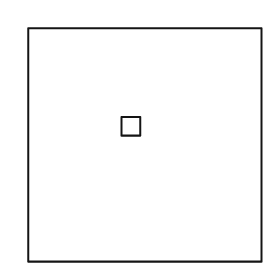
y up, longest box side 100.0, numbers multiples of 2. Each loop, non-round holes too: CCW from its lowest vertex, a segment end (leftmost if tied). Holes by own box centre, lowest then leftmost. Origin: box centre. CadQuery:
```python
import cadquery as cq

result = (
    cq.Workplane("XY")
    .moveTo(-50.0, -50.0)
    .lineTo(50.0, -50.0)
    .lineTo(50.0, 50.0)
    .lineTo(-50.0, 50.0)
    .close()
    .moveTo(-10.0, 4.0)
    .lineTo(-2.0, 4.0)
    .lineTo(-2.0, 12.0)
    .lineTo(-10.0, 12.0)
    .close()
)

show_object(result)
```